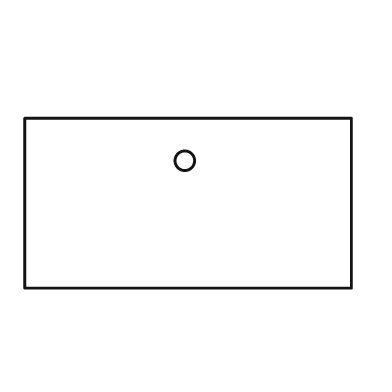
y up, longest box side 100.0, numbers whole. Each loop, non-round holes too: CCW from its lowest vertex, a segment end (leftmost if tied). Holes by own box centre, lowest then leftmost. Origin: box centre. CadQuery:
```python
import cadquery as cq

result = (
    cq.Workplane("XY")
    .moveTo(-50.0, -26.0)
    .lineTo(50.0, -26.0)
    .lineTo(50.0, 26.0)
    .lineTo(-50.0, 26.0)
    .close()
    .moveTo(-1.0, 13.0)
    .circle(3.0)
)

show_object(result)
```